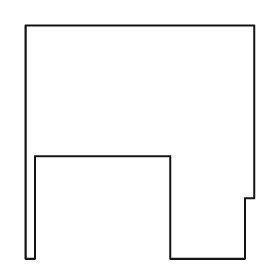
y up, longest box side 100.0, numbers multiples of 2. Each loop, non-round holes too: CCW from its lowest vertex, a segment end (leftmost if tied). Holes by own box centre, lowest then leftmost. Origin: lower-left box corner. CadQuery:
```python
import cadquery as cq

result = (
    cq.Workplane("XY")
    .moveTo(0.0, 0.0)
    .lineTo(4.0, 0.0)
    .lineTo(4.0, 44.0)
    .lineTo(62.0, 44.0)
    .lineTo(62.0, 0.0)
    .lineTo(94.0, 0.0)
    .lineTo(94.0, 26.0)
    .lineTo(98.0, 26.0)
    .lineTo(98.0, 100.0)
    .lineTo(0.0, 100.0)
    .close()
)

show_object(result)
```